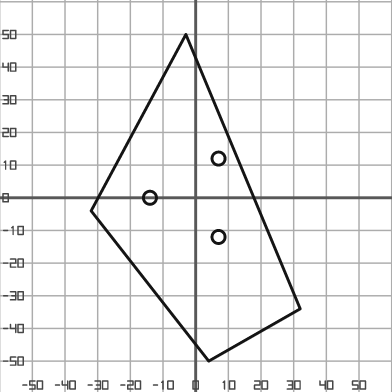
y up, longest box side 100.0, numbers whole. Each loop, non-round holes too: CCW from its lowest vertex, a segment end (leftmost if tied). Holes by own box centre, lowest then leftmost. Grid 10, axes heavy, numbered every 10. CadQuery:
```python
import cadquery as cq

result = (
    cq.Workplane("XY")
    .moveTo(4.0, -50.0)
    .lineTo(32.0, -34.0)
    .lineTo(-3.0, 50.0)
    .lineTo(-32.0, -4.0)
    .close()
    .moveTo(7.0, -12.0)
    .circle(2.0)
    .moveTo(-14.0, 0.0)
    .circle(2.0)
    .moveTo(7.0, 12.0)
    .circle(2.0)
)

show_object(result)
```